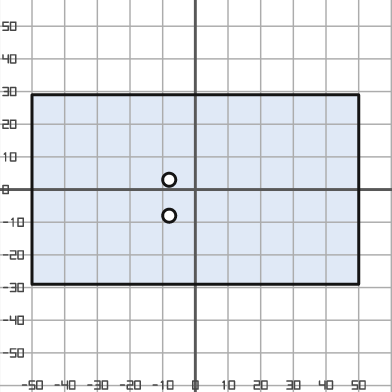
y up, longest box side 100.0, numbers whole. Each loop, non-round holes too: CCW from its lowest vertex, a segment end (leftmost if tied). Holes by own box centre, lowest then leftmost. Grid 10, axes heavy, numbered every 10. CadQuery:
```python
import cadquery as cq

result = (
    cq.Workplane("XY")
    .moveTo(-50.0, -29.0)
    .lineTo(50.0, -29.0)
    .lineTo(50.0, 29.0)
    .lineTo(-50.0, 29.0)
    .close()
    .moveTo(-8.0, -8.0)
    .circle(2.0)
    .moveTo(-8.0, 3.0)
    .circle(2.0)
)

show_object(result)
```